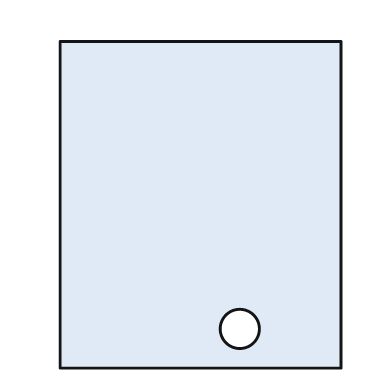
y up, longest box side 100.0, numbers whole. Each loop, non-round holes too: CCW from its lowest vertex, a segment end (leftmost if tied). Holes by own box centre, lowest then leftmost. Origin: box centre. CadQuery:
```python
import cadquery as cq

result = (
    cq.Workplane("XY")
    .moveTo(-43.0, -50.0)
    .lineTo(43.0, -50.0)
    .lineTo(43.0, 50.0)
    .lineTo(-43.0, 50.0)
    .close()
    .moveTo(12.0, -38.0)
    .circle(6.0)
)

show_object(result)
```